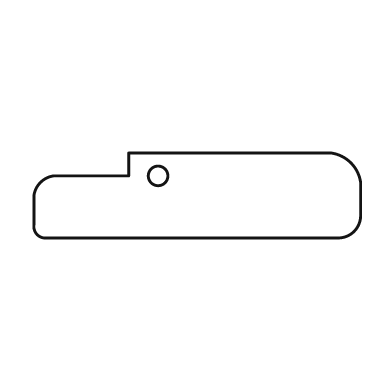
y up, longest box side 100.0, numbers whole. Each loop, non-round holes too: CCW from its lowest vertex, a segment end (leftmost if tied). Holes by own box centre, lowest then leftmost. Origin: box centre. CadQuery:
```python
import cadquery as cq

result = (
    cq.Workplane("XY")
    .moveTo(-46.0, -13.0)
    .lineTo(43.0, -13.0)
    .threePointArc((48.0, -11.0), (50.0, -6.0))
    .lineTo(50.0, 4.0)
    .threePointArc((47.0, 10.0), (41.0, 13.0))
    .lineTo(-21.0, 13.0)
    .lineTo(-21.0, 6.0)
    .lineTo(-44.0, 6.0)
    .threePointArc((-48.0, 4.0), (-50.0, 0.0))
    .lineTo(-50.0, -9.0)
    .threePointArc((-49.0, -12.0), (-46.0, -13.0))
    .close()
    .moveTo(-12.0, 6.0)
    .circle(3.0)
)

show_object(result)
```